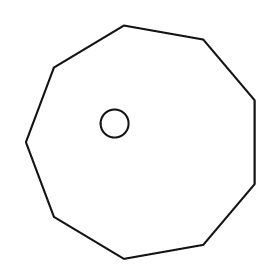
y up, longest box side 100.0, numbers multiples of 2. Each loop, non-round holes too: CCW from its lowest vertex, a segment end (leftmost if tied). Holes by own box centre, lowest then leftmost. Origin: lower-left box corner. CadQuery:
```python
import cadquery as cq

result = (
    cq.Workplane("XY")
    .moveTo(42.0, 0.0)
    .lineTo(76.0, 6.0)
    .lineTo(98.0, 32.0)
    .lineTo(98.0, 68.0)
    .lineTo(76.0, 94.0)
    .lineTo(42.0, 100.0)
    .lineTo(12.0, 82.0)
    .lineTo(0.0, 50.0)
    .lineTo(12.0, 18.0)
    .close()
    .moveTo(38.0, 58.0)
    .circle(6.0)
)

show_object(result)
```